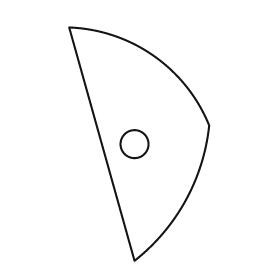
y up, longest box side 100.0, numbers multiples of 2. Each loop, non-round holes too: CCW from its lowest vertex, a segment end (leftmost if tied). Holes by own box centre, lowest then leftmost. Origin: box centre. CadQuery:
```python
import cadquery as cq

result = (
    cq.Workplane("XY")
    .moveTo(-2.0, -50.0)
    .threePointArc((20.0, -24.0), (30.0, 8.0))
    .threePointArc((6.0, 38.0), (-30.0, 50.0))
    .close()
    .moveTo(-2.0, 0.0)
    .circle(6.0)
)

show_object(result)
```